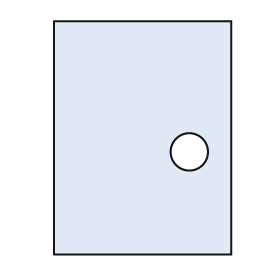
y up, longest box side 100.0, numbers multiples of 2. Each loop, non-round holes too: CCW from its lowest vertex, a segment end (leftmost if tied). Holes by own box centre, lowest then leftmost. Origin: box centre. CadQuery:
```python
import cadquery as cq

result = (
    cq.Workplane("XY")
    .moveTo(-38.0, -50.0)
    .lineTo(38.0, -50.0)
    .lineTo(38.0, 50.0)
    .lineTo(-38.0, 50.0)
    .close()
    .moveTo(20.0, -6.0)
    .circle(8.0)
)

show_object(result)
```